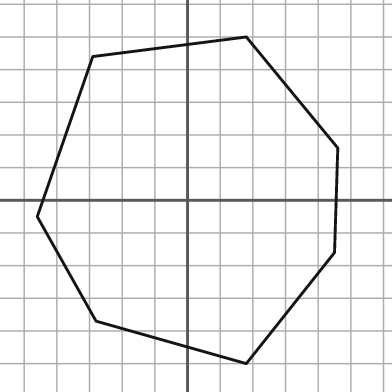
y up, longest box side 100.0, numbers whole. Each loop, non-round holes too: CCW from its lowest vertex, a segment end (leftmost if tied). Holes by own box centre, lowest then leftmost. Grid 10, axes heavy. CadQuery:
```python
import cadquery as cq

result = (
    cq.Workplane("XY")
    .moveTo(18.0, -50.0)
    .lineTo(45.0, -16.0)
    .lineTo(46.0, 16.0)
    .lineTo(18.0, 50.0)
    .lineTo(-29.0, 44.0)
    .lineTo(-46.0, -5.0)
    .lineTo(-28.0, -37.0)
    .close()
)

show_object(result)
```